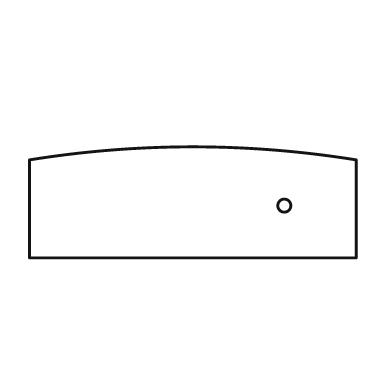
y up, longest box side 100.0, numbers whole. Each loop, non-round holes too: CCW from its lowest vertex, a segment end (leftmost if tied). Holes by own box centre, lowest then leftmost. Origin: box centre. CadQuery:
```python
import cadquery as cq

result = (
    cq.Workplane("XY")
    .moveTo(-50.0, -17.0)
    .lineTo(50.0, -17.0)
    .lineTo(50.0, 13.0)
    .threePointArc((0.0, 17.0), (-50.0, 13.0))
    .close()
    .moveTo(28.0, -1.0)
    .circle(2.0)
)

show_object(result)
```